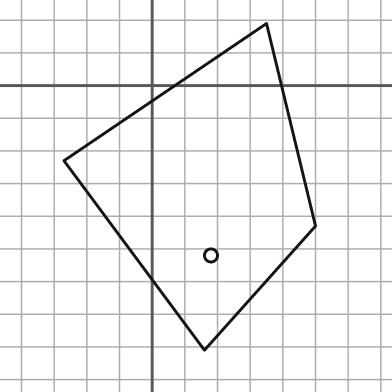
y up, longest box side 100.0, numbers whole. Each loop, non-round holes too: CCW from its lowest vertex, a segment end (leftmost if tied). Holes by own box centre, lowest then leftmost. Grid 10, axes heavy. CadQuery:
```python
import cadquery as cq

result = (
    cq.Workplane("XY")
    .moveTo(16.0, -81.0)
    .lineTo(50.0, -43.0)
    .lineTo(35.0, 19.0)
    .lineTo(-27.0, -23.0)
    .close()
    .moveTo(18.0, -52.0)
    .circle(2.0)
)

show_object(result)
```